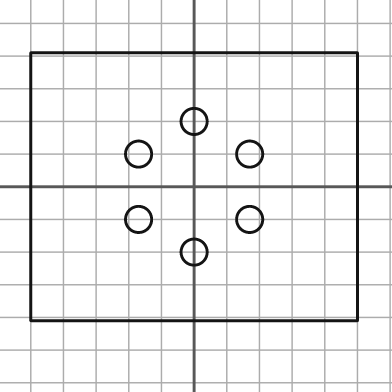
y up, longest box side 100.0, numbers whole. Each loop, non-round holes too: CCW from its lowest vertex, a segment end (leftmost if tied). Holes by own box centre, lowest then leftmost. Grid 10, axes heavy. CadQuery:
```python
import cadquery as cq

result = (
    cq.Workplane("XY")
    .moveTo(-50.0, -41.0)
    .lineTo(50.0, -41.0)
    .lineTo(50.0, 41.0)
    .lineTo(-50.0, 41.0)
    .close()
    .moveTo(0.0, -20.0)
    .circle(4.0)
    .moveTo(-17.0, -10.0)
    .circle(4.0)
    .moveTo(17.0, -10.0)
    .circle(4.0)
    .moveTo(-17.0, 10.0)
    .circle(4.0)
    .moveTo(17.0, 10.0)
    .circle(4.0)
    .moveTo(0.0, 20.0)
    .circle(4.0)
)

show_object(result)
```